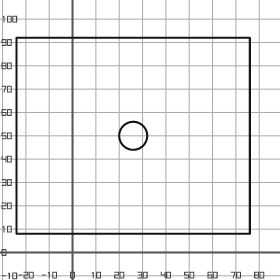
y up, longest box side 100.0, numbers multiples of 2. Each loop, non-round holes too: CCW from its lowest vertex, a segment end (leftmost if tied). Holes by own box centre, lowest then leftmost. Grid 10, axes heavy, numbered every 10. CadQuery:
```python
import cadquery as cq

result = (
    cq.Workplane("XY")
    .moveTo(-24.0, 8.0)
    .lineTo(76.0, 8.0)
    .lineTo(76.0, 92.0)
    .lineTo(-24.0, 92.0)
    .close()
    .moveTo(26.0, 50.0)
    .circle(6.0)
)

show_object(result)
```